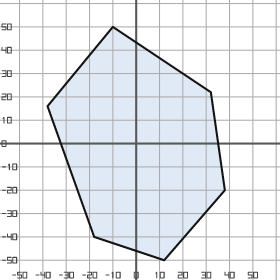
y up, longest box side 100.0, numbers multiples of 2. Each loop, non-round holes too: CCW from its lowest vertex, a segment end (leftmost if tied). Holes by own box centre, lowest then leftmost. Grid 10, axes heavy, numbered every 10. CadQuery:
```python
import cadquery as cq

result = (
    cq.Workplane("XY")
    .moveTo(12.0, -50.0)
    .lineTo(38.0, -20.0)
    .lineTo(32.0, 22.0)
    .lineTo(-10.0, 50.0)
    .lineTo(-38.0, 16.0)
    .lineTo(-18.0, -40.0)
    .close()
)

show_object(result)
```